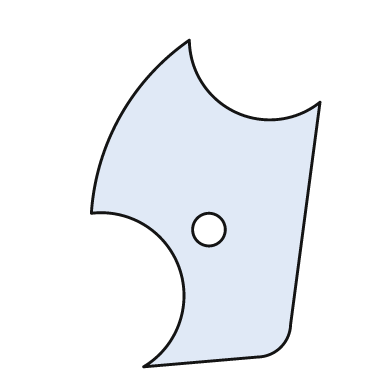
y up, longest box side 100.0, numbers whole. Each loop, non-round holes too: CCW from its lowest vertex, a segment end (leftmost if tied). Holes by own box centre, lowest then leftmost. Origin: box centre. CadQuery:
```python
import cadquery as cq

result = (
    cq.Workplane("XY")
    .moveTo(-19.0, -50.0)
    .lineTo(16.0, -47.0)
    .threePointArc((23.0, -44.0), (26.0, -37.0))
    .lineTo(35.0, 31.0)
    .threePointArc((9.0, 28.0), (-5.0, 50.0))
    .threePointArc((-26.0, 27.0), (-35.0, -3.0))
    .threePointArc((-8.0, -20.0), (-19.0, -50.0))
    .close()
    .moveTo(1.0, -8.0)
    .circle(5.0)
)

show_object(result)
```